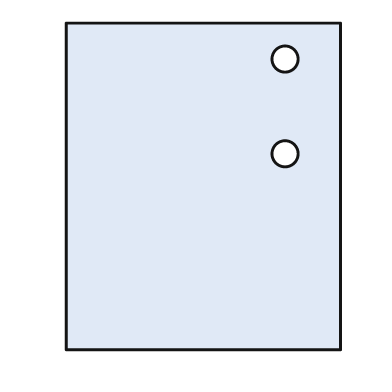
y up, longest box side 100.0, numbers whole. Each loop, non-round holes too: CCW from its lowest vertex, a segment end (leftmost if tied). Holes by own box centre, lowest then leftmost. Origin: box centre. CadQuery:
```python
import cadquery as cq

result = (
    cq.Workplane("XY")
    .moveTo(-42.0, -50.0)
    .lineTo(42.0, -50.0)
    .lineTo(42.0, 50.0)
    .lineTo(-42.0, 50.0)
    .close()
    .moveTo(25.0, 10.0)
    .circle(4.0)
    .moveTo(25.0, 39.0)
    .circle(4.0)
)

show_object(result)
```